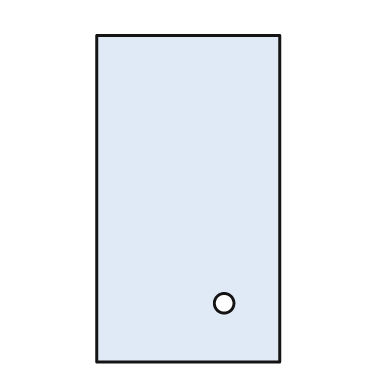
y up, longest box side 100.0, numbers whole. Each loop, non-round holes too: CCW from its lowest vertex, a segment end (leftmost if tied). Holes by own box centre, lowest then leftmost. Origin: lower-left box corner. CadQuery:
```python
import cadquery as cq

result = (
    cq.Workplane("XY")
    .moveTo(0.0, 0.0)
    .lineTo(56.0, 0.0)
    .lineTo(56.0, 100.0)
    .lineTo(0.0, 100.0)
    .close()
    .moveTo(39.0, 18.0)
    .circle(3.0)
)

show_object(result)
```